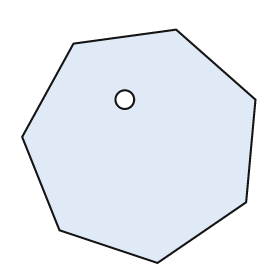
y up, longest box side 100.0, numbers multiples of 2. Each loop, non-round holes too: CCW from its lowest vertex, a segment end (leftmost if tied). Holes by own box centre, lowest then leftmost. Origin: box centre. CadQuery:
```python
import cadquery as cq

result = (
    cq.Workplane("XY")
    .moveTo(8.0, -50.0)
    .lineTo(46.0, -24.0)
    .lineTo(50.0, 20.0)
    .lineTo(16.0, 50.0)
    .lineTo(-28.0, 44.0)
    .lineTo(-50.0, 4.0)
    .lineTo(-34.0, -36.0)
    .close()
    .moveTo(-6.0, 20.0)
    .circle(4.0)
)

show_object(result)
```